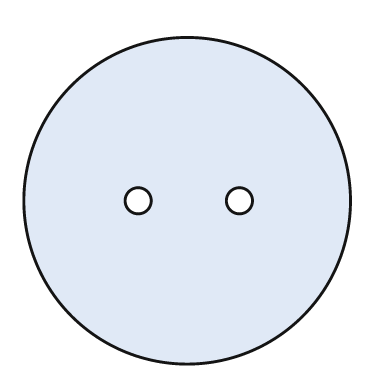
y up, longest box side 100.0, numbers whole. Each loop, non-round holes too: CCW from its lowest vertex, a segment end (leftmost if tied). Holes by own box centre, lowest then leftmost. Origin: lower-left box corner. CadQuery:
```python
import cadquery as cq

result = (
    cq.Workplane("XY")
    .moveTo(50.0, 50.0)
    .circle(50.0)
    .moveTo(35.0, 50.0)
    .circle(4.0)
    .moveTo(66.0, 50.0)
    .circle(4.0)
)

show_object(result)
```